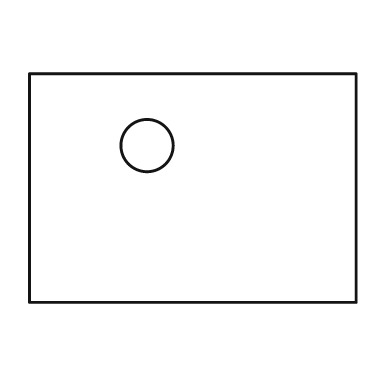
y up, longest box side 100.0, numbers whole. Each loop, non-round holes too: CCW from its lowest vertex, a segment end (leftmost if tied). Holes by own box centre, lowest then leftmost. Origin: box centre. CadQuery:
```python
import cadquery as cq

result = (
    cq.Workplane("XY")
    .moveTo(-50.0, -35.0)
    .lineTo(50.0, -35.0)
    .lineTo(50.0, 35.0)
    .lineTo(-50.0, 35.0)
    .close()
    .moveTo(-14.0, 13.0)
    .circle(8.0)
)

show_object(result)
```